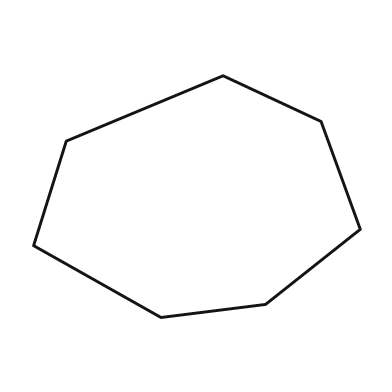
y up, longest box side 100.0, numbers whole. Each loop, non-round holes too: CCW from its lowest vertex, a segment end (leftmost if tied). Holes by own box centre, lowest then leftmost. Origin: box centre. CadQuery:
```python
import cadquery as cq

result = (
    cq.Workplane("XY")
    .moveTo(-11.0, -37.0)
    .lineTo(21.0, -33.0)
    .lineTo(50.0, -10.0)
    .lineTo(38.0, 23.0)
    .lineTo(8.0, 37.0)
    .lineTo(-40.0, 17.0)
    .lineTo(-50.0, -15.0)
    .close()
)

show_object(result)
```